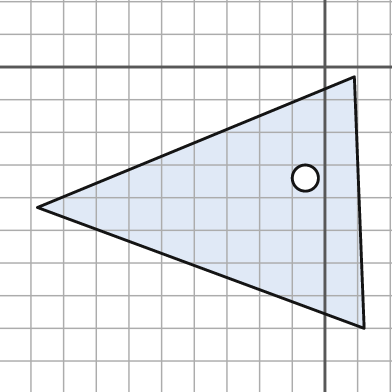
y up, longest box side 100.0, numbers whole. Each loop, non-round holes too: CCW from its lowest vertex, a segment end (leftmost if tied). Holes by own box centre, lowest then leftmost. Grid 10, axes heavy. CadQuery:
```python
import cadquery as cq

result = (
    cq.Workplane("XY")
    .moveTo(12.0, -80.0)
    .lineTo(9.0, -3.0)
    .lineTo(-88.0, -43.0)
    .close()
    .moveTo(-6.0, -34.0)
    .circle(4.0)
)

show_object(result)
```